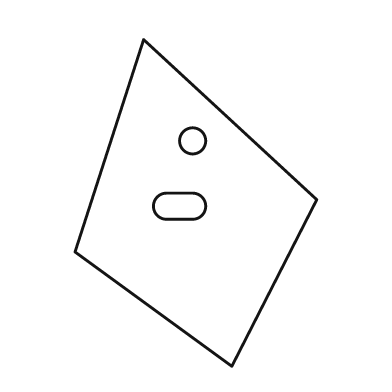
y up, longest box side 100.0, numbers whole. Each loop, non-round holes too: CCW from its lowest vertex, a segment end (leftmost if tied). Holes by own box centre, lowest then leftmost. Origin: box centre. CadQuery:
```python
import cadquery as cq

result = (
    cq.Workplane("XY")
    .moveTo(11.0, -50.0)
    .lineTo(37.0, 1.0)
    .lineTo(-16.0, 50.0)
    .lineTo(-37.0, -15.0)
    .close()
    .moveTo(-9.0, -5.0)
    .lineTo(-1.0, -5.0)
    .threePointArc((3.0, -1.0), (-1.0, 3.0))
    .lineTo(-9.0, 3.0)
    .threePointArc((-13.0, -1.0), (-9.0, -5.0))
    .close()
    .moveTo(-1.0, 19.0)
    .circle(4.0)
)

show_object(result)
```